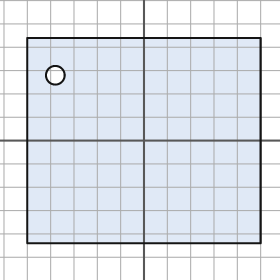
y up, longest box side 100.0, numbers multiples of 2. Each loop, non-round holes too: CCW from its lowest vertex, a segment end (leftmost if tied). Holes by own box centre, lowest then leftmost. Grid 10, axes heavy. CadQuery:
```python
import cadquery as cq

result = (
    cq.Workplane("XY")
    .moveTo(-50.0, -44.0)
    .lineTo(50.0, -44.0)
    .lineTo(50.0, 44.0)
    .lineTo(-50.0, 44.0)
    .close()
    .moveTo(-38.0, 28.0)
    .circle(4.0)
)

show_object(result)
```